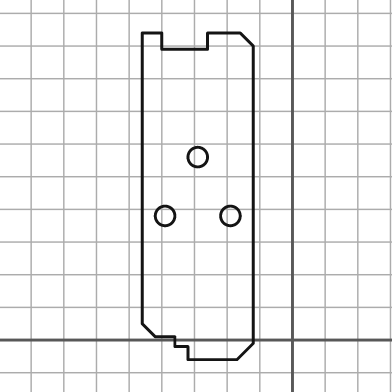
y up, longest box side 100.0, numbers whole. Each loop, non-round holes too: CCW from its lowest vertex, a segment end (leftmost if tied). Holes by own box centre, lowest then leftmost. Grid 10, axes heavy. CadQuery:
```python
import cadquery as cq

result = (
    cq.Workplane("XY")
    .moveTo(-32.0, -6.0)
    .lineTo(-17.0, -6.0)
    .lineTo(-12.0, -1.0)
    .lineTo(-12.0, 90.0)
    .lineTo(-16.0, 94.0)
    .lineTo(-26.0, 94.0)
    .lineTo(-26.0, 89.0)
    .lineTo(-40.0, 89.0)
    .lineTo(-40.0, 94.0)
    .lineTo(-46.0, 94.0)
    .lineTo(-46.0, 5.0)
    .lineTo(-42.0, 1.0)
    .lineTo(-36.0, 1.0)
    .lineTo(-36.0, -2.0)
    .lineTo(-32.0, -2.0)
    .close()
    .moveTo(-39.0, 38.0)
    .circle(3.0)
    .moveTo(-19.0, 38.0)
    .circle(3.0)
    .moveTo(-29.0, 56.0)
    .circle(3.0)
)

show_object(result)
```